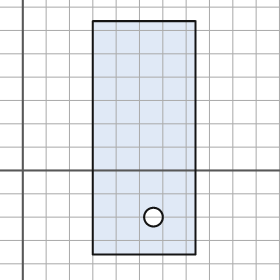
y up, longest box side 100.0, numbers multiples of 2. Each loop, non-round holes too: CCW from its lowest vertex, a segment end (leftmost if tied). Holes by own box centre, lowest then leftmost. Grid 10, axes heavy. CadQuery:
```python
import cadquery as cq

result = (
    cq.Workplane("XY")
    .moveTo(30.0, -36.0)
    .lineTo(74.0, -36.0)
    .lineTo(74.0, 64.0)
    .lineTo(30.0, 64.0)
    .close()
    .moveTo(56.0, -20.0)
    .circle(4.0)
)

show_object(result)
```